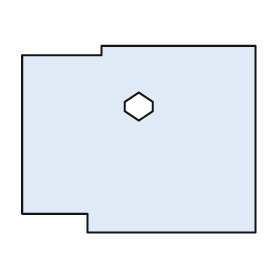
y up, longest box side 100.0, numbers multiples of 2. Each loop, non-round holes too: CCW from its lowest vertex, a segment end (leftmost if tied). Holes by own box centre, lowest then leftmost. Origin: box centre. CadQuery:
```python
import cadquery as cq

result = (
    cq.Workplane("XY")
    .moveTo(-22.0, -40.0)
    .lineTo(50.0, -40.0)
    .lineTo(50.0, 40.0)
    .lineTo(-16.0, 40.0)
    .lineTo(-16.0, 36.0)
    .lineTo(-50.0, 36.0)
    .lineTo(-50.0, -32.0)
    .lineTo(-22.0, -32.0)
    .close()
    .moveTo(0.0, 8.0)
    .lineTo(6.0, 12.0)
    .lineTo(6.0, 16.0)
    .lineTo(0.0, 20.0)
    .lineTo(-6.0, 16.0)
    .lineTo(-6.0, 12.0)
    .close()
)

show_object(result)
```